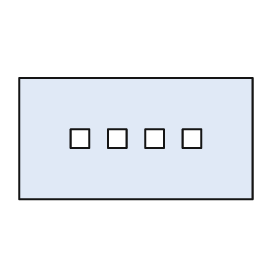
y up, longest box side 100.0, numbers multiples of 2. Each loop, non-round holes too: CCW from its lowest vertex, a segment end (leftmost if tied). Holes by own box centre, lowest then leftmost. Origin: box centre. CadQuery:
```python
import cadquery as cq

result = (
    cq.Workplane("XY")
    .moveTo(-50.0, -26.0)
    .lineTo(50.0, -26.0)
    .lineTo(50.0, 26.0)
    .lineTo(-50.0, 26.0)
    .close()
    .moveTo(-28.0, -4.0)
    .lineTo(-20.0, -4.0)
    .lineTo(-20.0, 4.0)
    .lineTo(-28.0, 4.0)
    .close()
    .moveTo(-12.0, -4.0)
    .lineTo(-4.0, -4.0)
    .lineTo(-4.0, 4.0)
    .lineTo(-12.0, 4.0)
    .close()
    .moveTo(4.0, -4.0)
    .lineTo(12.0, -4.0)
    .lineTo(12.0, 4.0)
    .lineTo(4.0, 4.0)
    .close()
    .moveTo(20.0, -4.0)
    .lineTo(28.0, -4.0)
    .lineTo(28.0, 4.0)
    .lineTo(20.0, 4.0)
    .close()
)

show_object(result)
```